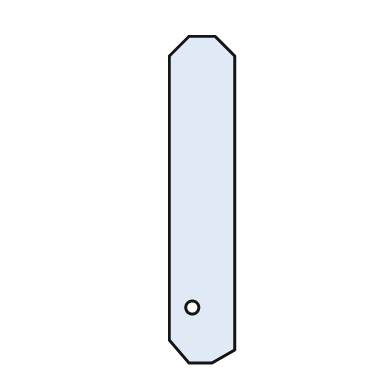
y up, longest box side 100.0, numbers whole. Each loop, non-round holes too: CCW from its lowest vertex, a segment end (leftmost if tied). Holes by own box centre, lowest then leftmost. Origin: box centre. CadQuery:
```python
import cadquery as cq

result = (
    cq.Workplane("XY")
    .moveTo(-4.0, -50.0)
    .lineTo(3.0, -50.0)
    .lineTo(10.0, -46.0)
    .lineTo(10.0, 44.0)
    .lineTo(4.0, 50.0)
    .lineTo(-4.0, 50.0)
    .lineTo(-10.0, 44.0)
    .lineTo(-10.0, -43.0)
    .close()
    .moveTo(-3.0, -33.0)
    .circle(2.0)
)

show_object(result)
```